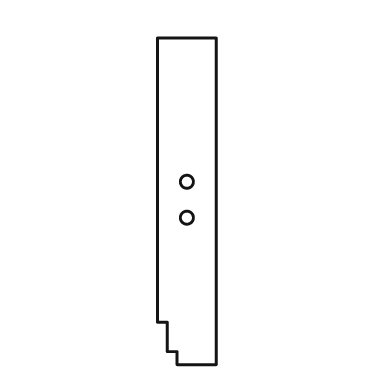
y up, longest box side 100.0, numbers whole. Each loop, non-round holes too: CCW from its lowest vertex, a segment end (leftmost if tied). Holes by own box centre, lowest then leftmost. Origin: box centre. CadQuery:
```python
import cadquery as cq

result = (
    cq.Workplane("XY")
    .moveTo(-3.0, -50.0)
    .lineTo(9.0, -50.0)
    .lineTo(9.0, 50.0)
    .lineTo(-9.0, 50.0)
    .lineTo(-9.0, -37.0)
    .lineTo(-6.0, -37.0)
    .lineTo(-6.0, -46.0)
    .lineTo(-3.0, -46.0)
    .close()
    .moveTo(0.0, -5.0)
    .circle(2.0)
    .moveTo(0.0, 6.0)
    .circle(2.0)
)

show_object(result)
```